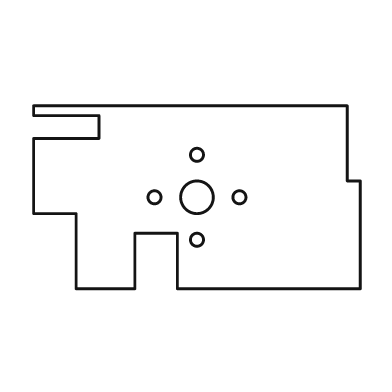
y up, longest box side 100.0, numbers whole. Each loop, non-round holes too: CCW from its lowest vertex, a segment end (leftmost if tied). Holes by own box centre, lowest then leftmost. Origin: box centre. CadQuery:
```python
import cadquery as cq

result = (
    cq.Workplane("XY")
    .moveTo(-37.0, -28.0)
    .lineTo(-19.0, -28.0)
    .lineTo(-19.0, -11.0)
    .lineTo(-6.0, -11.0)
    .lineTo(-6.0, -28.0)
    .lineTo(50.0, -28.0)
    .lineTo(50.0, 5.0)
    .lineTo(46.0, 5.0)
    .lineTo(46.0, 28.0)
    .lineTo(-50.0, 28.0)
    .lineTo(-50.0, 25.0)
    .lineTo(-30.0, 25.0)
    .lineTo(-30.0, 18.0)
    .lineTo(-50.0, 18.0)
    .lineTo(-50.0, -5.0)
    .lineTo(-37.0, -5.0)
    .close()
    .moveTo(0.0, -13.0)
    .circle(2.0)
    .moveTo(-13.0, 0.0)
    .circle(2.0)
    .moveTo(0.0, 0.0)
    .circle(5.0)
    .moveTo(13.0, 0.0)
    .circle(2.0)
    .moveTo(0.0, 13.0)
    .circle(2.0)
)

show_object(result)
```